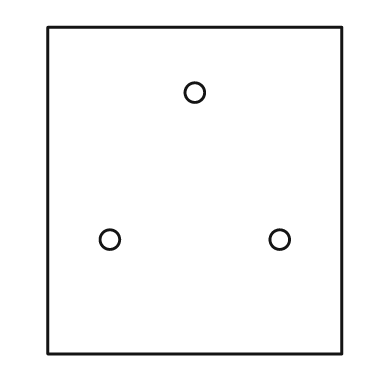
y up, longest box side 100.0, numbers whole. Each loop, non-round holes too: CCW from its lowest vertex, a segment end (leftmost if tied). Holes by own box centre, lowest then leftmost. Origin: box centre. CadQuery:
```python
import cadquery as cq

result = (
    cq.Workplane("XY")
    .moveTo(-45.0, -50.0)
    .lineTo(45.0, -50.0)
    .lineTo(45.0, 50.0)
    .lineTo(-45.0, 50.0)
    .close()
    .moveTo(-26.0, -15.0)
    .circle(3.0)
    .moveTo(26.0, -15.0)
    .circle(3.0)
    .moveTo(0.0, 30.0)
    .circle(3.0)
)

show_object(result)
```